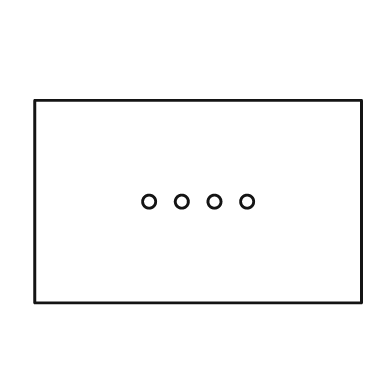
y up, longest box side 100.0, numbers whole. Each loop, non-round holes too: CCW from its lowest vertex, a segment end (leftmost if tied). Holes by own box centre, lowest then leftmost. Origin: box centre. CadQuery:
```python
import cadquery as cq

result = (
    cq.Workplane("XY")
    .moveTo(-50.0, -31.0)
    .lineTo(50.0, -31.0)
    .lineTo(50.0, 31.0)
    .lineTo(-50.0, 31.0)
    .close()
    .moveTo(-15.0, 0.0)
    .circle(2.0)
    .moveTo(-5.0, 0.0)
    .circle(2.0)
    .moveTo(5.0, 0.0)
    .circle(2.0)
    .moveTo(15.0, 0.0)
    .circle(2.0)
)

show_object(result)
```